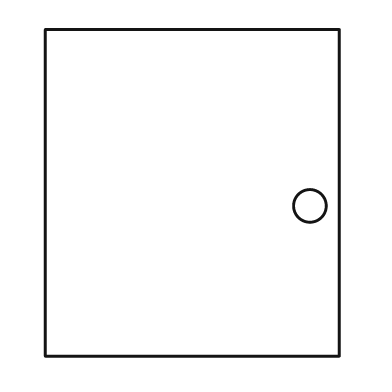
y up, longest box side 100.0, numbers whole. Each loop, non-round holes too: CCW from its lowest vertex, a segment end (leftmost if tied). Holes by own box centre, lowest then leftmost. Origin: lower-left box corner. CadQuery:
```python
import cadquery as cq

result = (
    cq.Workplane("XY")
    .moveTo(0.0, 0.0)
    .lineTo(90.0, 0.0)
    .lineTo(90.0, 100.0)
    .lineTo(0.0, 100.0)
    .close()
    .moveTo(81.0, 46.0)
    .circle(5.0)
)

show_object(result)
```